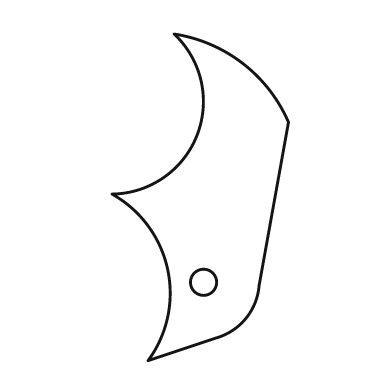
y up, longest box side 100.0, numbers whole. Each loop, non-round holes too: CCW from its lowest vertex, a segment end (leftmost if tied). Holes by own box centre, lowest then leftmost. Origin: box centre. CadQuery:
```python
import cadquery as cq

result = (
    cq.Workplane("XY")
    .moveTo(-16.0, -50.0)
    .lineTo(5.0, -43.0)
    .threePointArc((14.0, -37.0), (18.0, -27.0))
    .lineTo(27.0, 23.0)
    .threePointArc((13.0, 41.0), (-8.0, 50.0))
    .threePointArc((-1.0, 19.0), (-27.0, 1.0))
    .threePointArc((-10.0, -22.0), (-16.0, -50.0))
    .close()
    .moveTo(1.0, -26.0)
    .circle(4.0)
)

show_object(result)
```